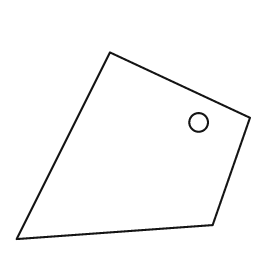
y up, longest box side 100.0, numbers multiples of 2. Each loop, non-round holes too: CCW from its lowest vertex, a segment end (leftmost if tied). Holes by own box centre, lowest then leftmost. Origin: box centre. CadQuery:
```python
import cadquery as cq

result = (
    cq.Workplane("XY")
    .moveTo(-50.0, -40.0)
    .lineTo(34.0, -34.0)
    .lineTo(50.0, 12.0)
    .lineTo(-10.0, 40.0)
    .close()
    .moveTo(28.0, 10.0)
    .circle(4.0)
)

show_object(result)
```